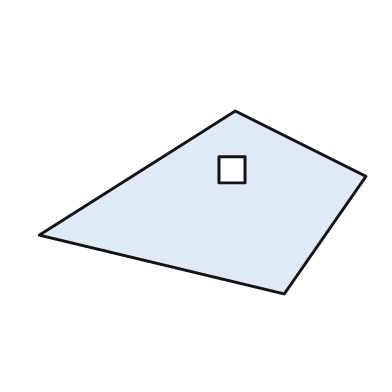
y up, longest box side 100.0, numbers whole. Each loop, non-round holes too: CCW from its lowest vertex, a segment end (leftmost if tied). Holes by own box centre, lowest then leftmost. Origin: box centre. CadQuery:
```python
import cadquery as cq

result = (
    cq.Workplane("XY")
    .moveTo(25.0, -28.0)
    .lineTo(50.0, 8.0)
    .lineTo(10.0, 28.0)
    .lineTo(-50.0, -10.0)
    .close()
    .moveTo(5.0, 6.0)
    .lineTo(13.0, 6.0)
    .lineTo(13.0, 14.0)
    .lineTo(5.0, 14.0)
    .close()
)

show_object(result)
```